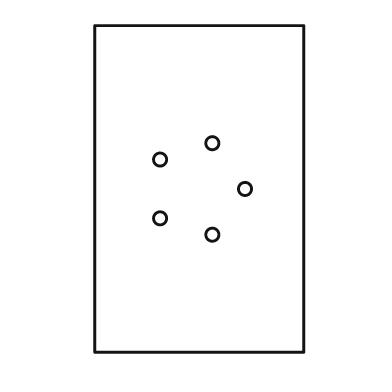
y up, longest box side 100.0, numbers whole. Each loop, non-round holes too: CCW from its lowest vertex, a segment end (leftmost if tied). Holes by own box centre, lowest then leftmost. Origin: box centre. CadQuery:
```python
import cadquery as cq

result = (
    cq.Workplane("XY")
    .moveTo(-32.0, -50.0)
    .lineTo(32.0, -50.0)
    .lineTo(32.0, 50.0)
    .lineTo(-32.0, 50.0)
    .close()
    .moveTo(4.0, -14.0)
    .circle(2.0)
    .moveTo(-12.0, -9.0)
    .circle(2.0)
    .moveTo(14.0, 0.0)
    .circle(2.0)
    .moveTo(-12.0, 9.0)
    .circle(2.0)
    .moveTo(4.0, 14.0)
    .circle(2.0)
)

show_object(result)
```